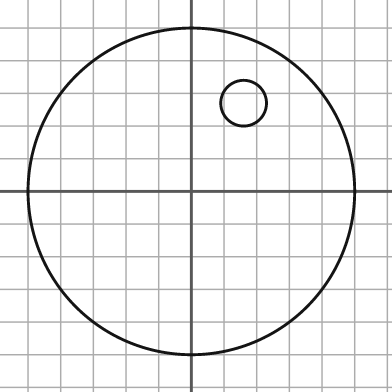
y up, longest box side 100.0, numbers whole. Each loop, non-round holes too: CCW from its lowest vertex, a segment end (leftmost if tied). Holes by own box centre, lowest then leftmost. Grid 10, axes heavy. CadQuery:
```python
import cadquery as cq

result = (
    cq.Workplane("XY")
    .moveTo(0.0, 0.0)
    .circle(50.0)
    .moveTo(16.0, 27.0)
    .circle(7.0)
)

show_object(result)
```